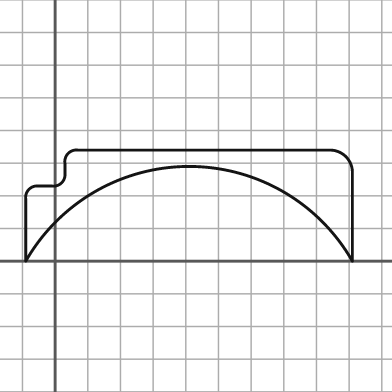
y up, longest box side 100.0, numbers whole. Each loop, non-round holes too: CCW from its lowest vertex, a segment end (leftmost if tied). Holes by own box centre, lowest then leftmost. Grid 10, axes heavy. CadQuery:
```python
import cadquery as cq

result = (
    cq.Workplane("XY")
    .moveTo(-9.0, 0.0)
    .threePointArc((41.0, 29.0), (91.0, 0.0))
    .lineTo(91.0, 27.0)
    .threePointArc((89.0, 32.0), (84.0, 34.0))
    .lineTo(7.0, 34.0)
    .threePointArc((4.0, 33.0), (3.0, 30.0))
    .lineTo(3.0, 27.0)
    .threePointArc((2.0, 24.0), (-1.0, 23.0))
    .lineTo(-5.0, 23.0)
    .threePointArc((-8.0, 22.0), (-9.0, 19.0))
    .close()
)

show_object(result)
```